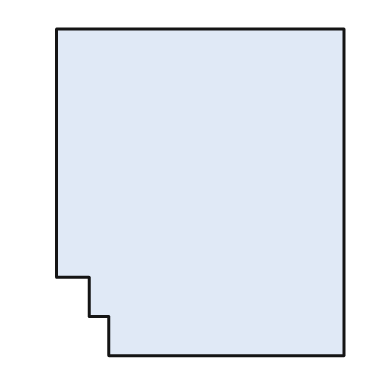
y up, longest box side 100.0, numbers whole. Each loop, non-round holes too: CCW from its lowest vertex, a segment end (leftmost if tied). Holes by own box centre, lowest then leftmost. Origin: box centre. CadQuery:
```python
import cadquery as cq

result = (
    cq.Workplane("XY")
    .moveTo(-28.0, -50.0)
    .lineTo(44.0, -50.0)
    .lineTo(44.0, 50.0)
    .lineTo(-44.0, 50.0)
    .lineTo(-44.0, -26.0)
    .lineTo(-34.0, -26.0)
    .lineTo(-34.0, -38.0)
    .lineTo(-28.0, -38.0)
    .close()
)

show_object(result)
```